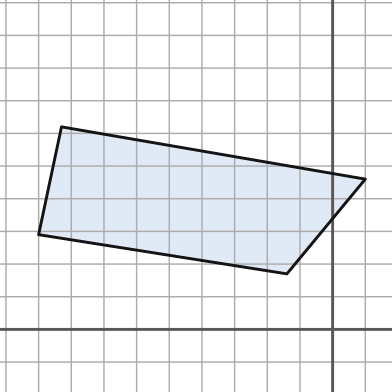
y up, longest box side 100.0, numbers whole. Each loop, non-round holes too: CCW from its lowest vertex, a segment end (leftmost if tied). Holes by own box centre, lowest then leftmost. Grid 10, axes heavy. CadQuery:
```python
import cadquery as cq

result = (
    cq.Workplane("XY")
    .moveTo(-14.0, 17.0)
    .lineTo(10.0, 46.0)
    .lineTo(-83.0, 62.0)
    .lineTo(-90.0, 29.0)
    .close()
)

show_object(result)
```